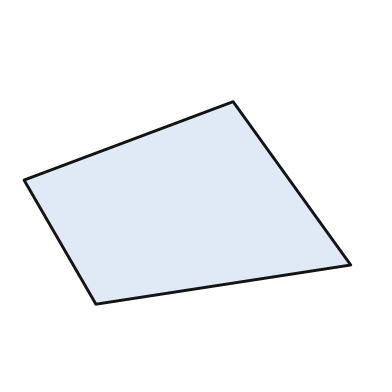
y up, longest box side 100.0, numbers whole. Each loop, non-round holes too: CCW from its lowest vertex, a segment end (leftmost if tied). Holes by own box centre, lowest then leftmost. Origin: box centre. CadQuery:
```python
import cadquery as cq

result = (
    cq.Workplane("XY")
    .moveTo(-28.0, -31.0)
    .lineTo(50.0, -19.0)
    .lineTo(14.0, 31.0)
    .lineTo(-50.0, 7.0)
    .close()
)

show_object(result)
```